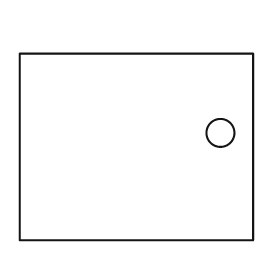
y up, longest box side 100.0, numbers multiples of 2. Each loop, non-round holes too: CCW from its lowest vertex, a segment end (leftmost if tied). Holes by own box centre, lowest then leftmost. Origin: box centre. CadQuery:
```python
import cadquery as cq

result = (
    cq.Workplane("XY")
    .moveTo(-50.0, -40.0)
    .lineTo(50.0, -40.0)
    .lineTo(50.0, 40.0)
    .lineTo(-50.0, 40.0)
    .close()
    .moveTo(36.0, 6.0)
    .circle(6.0)
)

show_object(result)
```